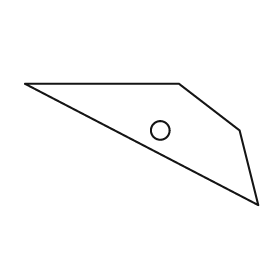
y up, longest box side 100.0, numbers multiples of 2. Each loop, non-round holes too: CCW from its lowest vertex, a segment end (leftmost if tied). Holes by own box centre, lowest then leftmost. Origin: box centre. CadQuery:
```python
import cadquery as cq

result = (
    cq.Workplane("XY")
    .moveTo(50.0, -26.0)
    .lineTo(42.0, 6.0)
    .lineTo(16.0, 26.0)
    .lineTo(-50.0, 26.0)
    .close()
    .moveTo(8.0, 6.0)
    .circle(4.0)
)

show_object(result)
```